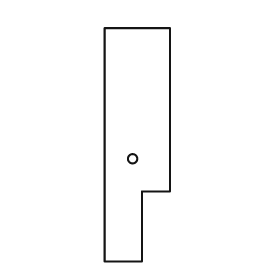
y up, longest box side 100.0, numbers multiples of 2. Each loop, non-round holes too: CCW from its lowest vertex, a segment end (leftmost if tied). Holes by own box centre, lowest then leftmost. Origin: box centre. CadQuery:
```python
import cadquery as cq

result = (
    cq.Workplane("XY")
    .moveTo(-14.0, -50.0)
    .lineTo(2.0, -50.0)
    .lineTo(2.0, -20.0)
    .lineTo(14.0, -20.0)
    .lineTo(14.0, 50.0)
    .lineTo(-14.0, 50.0)
    .close()
    .moveTo(-2.0, -6.0)
    .circle(2.0)
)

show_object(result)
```